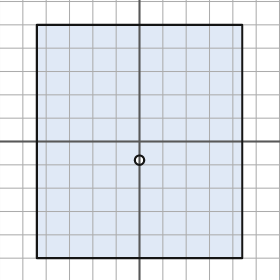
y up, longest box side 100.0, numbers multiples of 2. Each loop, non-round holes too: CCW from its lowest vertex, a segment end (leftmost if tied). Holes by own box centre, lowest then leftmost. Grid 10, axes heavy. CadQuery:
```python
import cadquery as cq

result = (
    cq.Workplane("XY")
    .moveTo(-44.0, -50.0)
    .lineTo(44.0, -50.0)
    .lineTo(44.0, 50.0)
    .lineTo(-44.0, 50.0)
    .close()
    .moveTo(0.0, -8.0)
    .circle(2.0)
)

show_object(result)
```